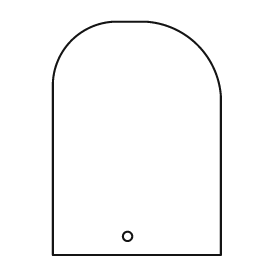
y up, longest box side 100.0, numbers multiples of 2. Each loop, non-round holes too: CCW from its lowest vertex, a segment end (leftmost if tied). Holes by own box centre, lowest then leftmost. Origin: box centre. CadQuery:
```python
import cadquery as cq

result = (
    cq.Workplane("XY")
    .moveTo(-36.0, -50.0)
    .lineTo(36.0, -50.0)
    .lineTo(36.0, 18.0)
    .threePointArc((26.0, 40.0), (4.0, 50.0))
    .lineTo(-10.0, 50.0)
    .threePointArc((-28.0, 42.0), (-36.0, 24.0))
    .close()
    .moveTo(-4.0, -42.0)
    .circle(2.0)
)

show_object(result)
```